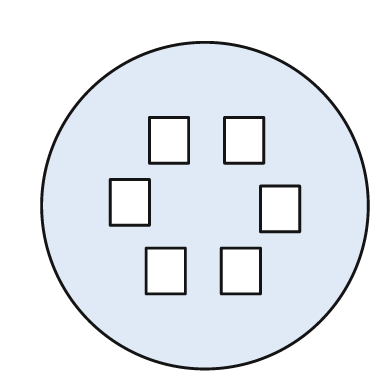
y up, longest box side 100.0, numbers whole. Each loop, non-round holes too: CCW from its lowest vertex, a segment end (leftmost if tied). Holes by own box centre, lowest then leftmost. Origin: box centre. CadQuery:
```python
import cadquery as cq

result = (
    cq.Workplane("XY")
    .moveTo(0.0, 0.0)
    .circle(50.0)
    .moveTo(-18.0, -27.0)
    .lineTo(-6.0, -27.0)
    .lineTo(-6.0, -13.0)
    .lineTo(-18.0, -13.0)
    .close()
    .moveTo(5.0, -27.0)
    .lineTo(17.0, -27.0)
    .lineTo(17.0, -13.0)
    .lineTo(5.0, -13.0)
    .close()
    .moveTo(17.0, -8.0)
    .lineTo(29.0, -8.0)
    .lineTo(29.0, 6.0)
    .lineTo(17.0, 6.0)
    .close()
    .moveTo(-29.0, -6.0)
    .lineTo(-17.0, -6.0)
    .lineTo(-17.0, 8.0)
    .lineTo(-29.0, 8.0)
    .close()
    .moveTo(-17.0, 13.0)
    .lineTo(-5.0, 13.0)
    .lineTo(-5.0, 27.0)
    .lineTo(-17.0, 27.0)
    .close()
    .moveTo(6.0, 13.0)
    .lineTo(18.0, 13.0)
    .lineTo(18.0, 27.0)
    .lineTo(6.0, 27.0)
    .close()
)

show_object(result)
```